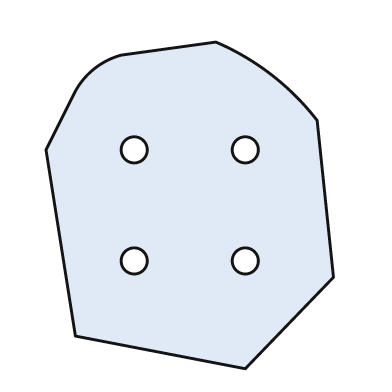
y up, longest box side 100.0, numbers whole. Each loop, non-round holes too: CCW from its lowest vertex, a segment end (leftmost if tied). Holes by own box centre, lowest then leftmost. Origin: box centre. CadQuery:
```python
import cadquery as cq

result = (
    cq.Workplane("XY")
    .moveTo(17.0, -50.0)
    .lineTo(44.0, -22.0)
    .lineTo(39.0, 26.0)
    .threePointArc((25.0, 40.0), (8.0, 50.0))
    .lineTo(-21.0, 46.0)
    .threePointArc((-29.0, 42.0), (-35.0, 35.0))
    .lineTo(-44.0, 17.0)
    .lineTo(-35.0, -40.0)
    .close()
    .moveTo(-17.0, -17.0)
    .circle(4.0)
    .moveTo(17.0, -17.0)
    .circle(4.0)
    .moveTo(-17.0, 17.0)
    .circle(4.0)
    .moveTo(17.0, 17.0)
    .circle(4.0)
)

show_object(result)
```